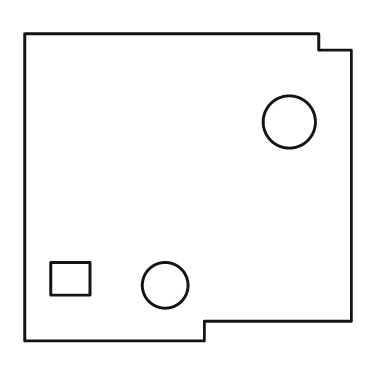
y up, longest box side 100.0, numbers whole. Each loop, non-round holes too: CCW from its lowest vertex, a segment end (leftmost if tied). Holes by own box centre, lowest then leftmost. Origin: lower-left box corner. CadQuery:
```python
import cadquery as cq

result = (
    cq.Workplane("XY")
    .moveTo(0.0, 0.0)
    .lineTo(55.0, 0.0)
    .lineTo(55.0, 6.0)
    .lineTo(100.0, 6.0)
    .lineTo(100.0, 89.0)
    .lineTo(90.0, 89.0)
    .lineTo(90.0, 94.0)
    .lineTo(0.0, 94.0)
    .close()
    .moveTo(43.0, 17.0)
    .circle(7.0)
    .moveTo(8.0, 14.0)
    .lineTo(20.0, 14.0)
    .lineTo(20.0, 24.0)
    .lineTo(8.0, 24.0)
    .close()
    .moveTo(81.0, 67.0)
    .circle(8.0)
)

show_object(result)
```